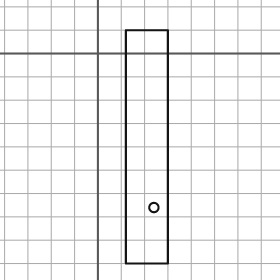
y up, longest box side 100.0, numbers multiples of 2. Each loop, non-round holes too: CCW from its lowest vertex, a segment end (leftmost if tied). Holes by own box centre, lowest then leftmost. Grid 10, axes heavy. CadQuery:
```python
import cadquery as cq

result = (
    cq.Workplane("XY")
    .moveTo(12.0, -90.0)
    .lineTo(30.0, -90.0)
    .lineTo(30.0, 10.0)
    .lineTo(12.0, 10.0)
    .close()
    .moveTo(24.0, -66.0)
    .circle(2.0)
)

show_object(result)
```